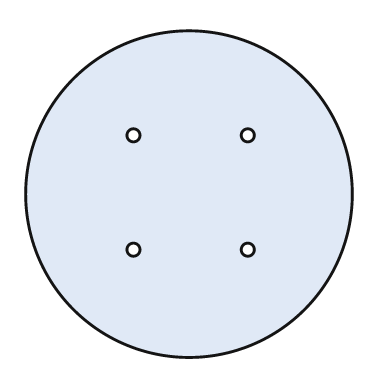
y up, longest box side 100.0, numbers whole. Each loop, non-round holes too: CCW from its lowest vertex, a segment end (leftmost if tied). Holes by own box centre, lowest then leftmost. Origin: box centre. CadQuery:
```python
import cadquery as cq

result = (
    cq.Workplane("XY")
    .moveTo(0.0, 0.0)
    .circle(50.0)
    .moveTo(-17.0, -17.0)
    .circle(2.0)
    .moveTo(18.0, -17.0)
    .circle(2.0)
    .moveTo(-17.0, 18.0)
    .circle(2.0)
    .moveTo(18.0, 18.0)
    .circle(2.0)
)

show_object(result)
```